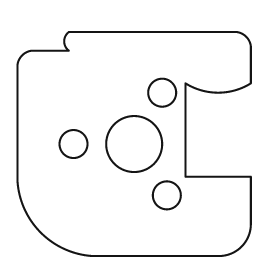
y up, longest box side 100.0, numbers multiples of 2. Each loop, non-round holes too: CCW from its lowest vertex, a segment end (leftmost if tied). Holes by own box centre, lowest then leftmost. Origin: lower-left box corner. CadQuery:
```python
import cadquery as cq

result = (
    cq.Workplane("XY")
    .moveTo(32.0, 0.0)
    .lineTo(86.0, 0.0)
    .threePointArc((96.0, 4.0), (100.0, 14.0))
    .lineTo(100.0, 34.0)
    .lineTo(72.0, 34.0)
    .lineTo(72.0, 74.0)
    .threePointArc((86.0, 70.0), (100.0, 74.0))
    .lineTo(100.0, 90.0)
    .threePointArc((98.0, 94.0), (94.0, 96.0))
    .lineTo(22.0, 96.0)
    .threePointArc((20.0, 92.0), (22.0, 88.0))
    .lineTo(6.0, 88.0)
    .threePointArc((2.0, 86.0), (0.0, 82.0))
    .lineTo(0.0, 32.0)
    .threePointArc((10.0, 10.0), (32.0, 0.0))
    .close()
    .moveTo(64.0, 26.0)
    .circle(6.0)
    .moveTo(24.0, 48.0)
    .circle(6.0)
    .moveTo(50.0, 48.0)
    .circle(12.0)
    .moveTo(62.0, 70.0)
    .circle(6.0)
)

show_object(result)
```